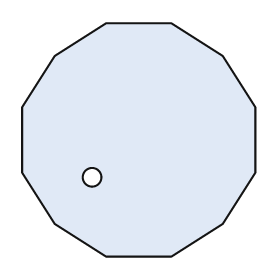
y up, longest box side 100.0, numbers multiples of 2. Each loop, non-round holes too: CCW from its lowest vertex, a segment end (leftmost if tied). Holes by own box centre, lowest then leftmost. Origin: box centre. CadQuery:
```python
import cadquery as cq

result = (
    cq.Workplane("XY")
    .moveTo(-14.0, -50.0)
    .lineTo(14.0, -50.0)
    .lineTo(36.0, -36.0)
    .lineTo(50.0, -14.0)
    .lineTo(50.0, 14.0)
    .lineTo(36.0, 36.0)
    .lineTo(14.0, 50.0)
    .lineTo(-14.0, 50.0)
    .lineTo(-36.0, 36.0)
    .lineTo(-50.0, 14.0)
    .lineTo(-50.0, -14.0)
    .lineTo(-36.0, -36.0)
    .close()
    .moveTo(-20.0, -16.0)
    .circle(4.0)
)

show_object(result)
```